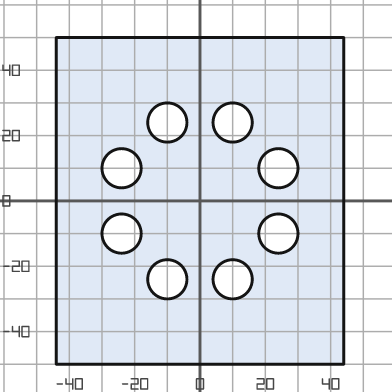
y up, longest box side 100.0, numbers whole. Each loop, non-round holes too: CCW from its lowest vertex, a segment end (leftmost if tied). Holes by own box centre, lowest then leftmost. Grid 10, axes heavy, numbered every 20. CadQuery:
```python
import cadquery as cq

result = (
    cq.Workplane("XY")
    .moveTo(-44.0, -50.0)
    .lineTo(44.0, -50.0)
    .lineTo(44.0, 50.0)
    .lineTo(-44.0, 50.0)
    .close()
    .moveTo(-10.0, -24.0)
    .circle(6.0)
    .moveTo(10.0, -24.0)
    .circle(6.0)
    .moveTo(-24.0, -10.0)
    .circle(6.0)
    .moveTo(24.0, -10.0)
    .circle(6.0)
    .moveTo(-24.0, 10.0)
    .circle(6.0)
    .moveTo(24.0, 10.0)
    .circle(6.0)
    .moveTo(-10.0, 24.0)
    .circle(6.0)
    .moveTo(10.0, 24.0)
    .circle(6.0)
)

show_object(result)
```